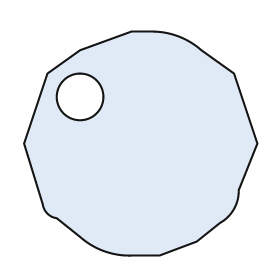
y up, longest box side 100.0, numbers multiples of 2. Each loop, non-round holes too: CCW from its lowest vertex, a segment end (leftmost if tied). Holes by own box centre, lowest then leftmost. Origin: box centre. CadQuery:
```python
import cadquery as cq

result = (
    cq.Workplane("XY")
    .moveTo(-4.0, -48.0)
    .lineTo(8.0, -48.0)
    .lineTo(24.0, -42.0)
    .lineTo(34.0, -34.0)
    .threePointArc((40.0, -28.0), (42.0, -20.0))
    .lineTo(50.0, 0.0)
    .lineTo(40.0, 30.0)
    .lineTo(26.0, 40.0)
    .threePointArc((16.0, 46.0), (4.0, 48.0))
    .lineTo(-4.0, 48.0)
    .lineTo(-26.0, 40.0)
    .lineTo(-40.0, 30.0)
    .lineTo(-50.0, 0.0)
    .lineTo(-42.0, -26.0)
    .threePointArc((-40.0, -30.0), (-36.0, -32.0))
    .lineTo(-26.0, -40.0)
    .threePointArc((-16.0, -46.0), (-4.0, -48.0))
    .close()
    .moveTo(-26.0, 20.0)
    .circle(10.0)
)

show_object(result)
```